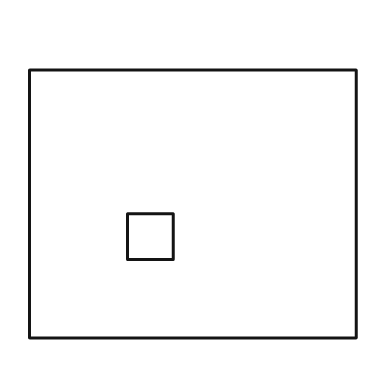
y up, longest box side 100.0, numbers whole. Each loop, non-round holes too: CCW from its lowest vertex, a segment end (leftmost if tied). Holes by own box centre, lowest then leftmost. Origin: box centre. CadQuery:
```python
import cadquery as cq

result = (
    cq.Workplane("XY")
    .moveTo(-50.0, -41.0)
    .lineTo(50.0, -41.0)
    .lineTo(50.0, 41.0)
    .lineTo(-50.0, 41.0)
    .close()
    .moveTo(-20.0, -17.0)
    .lineTo(-6.0, -17.0)
    .lineTo(-6.0, -3.0)
    .lineTo(-20.0, -3.0)
    .close()
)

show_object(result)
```